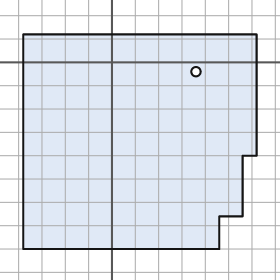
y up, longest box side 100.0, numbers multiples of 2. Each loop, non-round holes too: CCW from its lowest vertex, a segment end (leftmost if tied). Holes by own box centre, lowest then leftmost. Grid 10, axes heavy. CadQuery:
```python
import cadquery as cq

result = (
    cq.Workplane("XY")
    .moveTo(-38.0, -80.0)
    .lineTo(46.0, -80.0)
    .lineTo(46.0, -66.0)
    .lineTo(56.0, -66.0)
    .lineTo(56.0, -40.0)
    .lineTo(62.0, -40.0)
    .lineTo(62.0, 12.0)
    .lineTo(-38.0, 12.0)
    .close()
    .moveTo(36.0, -4.0)
    .circle(2.0)
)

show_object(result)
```